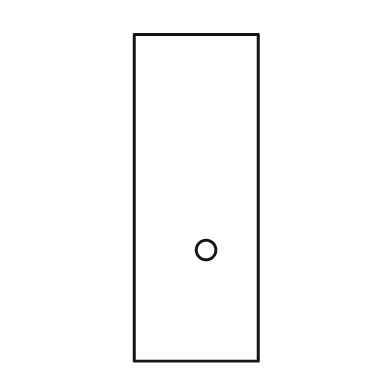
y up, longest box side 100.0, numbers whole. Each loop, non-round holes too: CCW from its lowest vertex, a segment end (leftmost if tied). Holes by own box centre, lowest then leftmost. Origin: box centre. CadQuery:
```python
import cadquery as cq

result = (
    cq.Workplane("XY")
    .moveTo(-19.0, -50.0)
    .lineTo(19.0, -50.0)
    .lineTo(19.0, 50.0)
    .lineTo(-19.0, 50.0)
    .close()
    .moveTo(3.0, -16.0)
    .circle(3.0)
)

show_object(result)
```